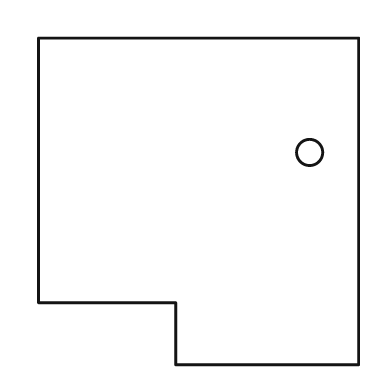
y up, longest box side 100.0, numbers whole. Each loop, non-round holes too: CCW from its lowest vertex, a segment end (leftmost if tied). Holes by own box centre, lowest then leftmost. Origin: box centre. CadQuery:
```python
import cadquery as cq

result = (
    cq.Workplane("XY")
    .moveTo(-7.0, -50.0)
    .lineTo(49.0, -50.0)
    .lineTo(49.0, 50.0)
    .lineTo(-49.0, 50.0)
    .lineTo(-49.0, -31.0)
    .lineTo(-7.0, -31.0)
    .close()
    .moveTo(34.0, 15.0)
    .circle(4.0)
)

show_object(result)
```